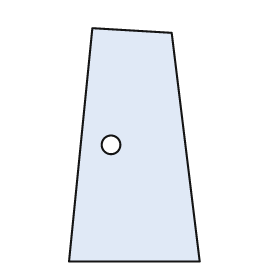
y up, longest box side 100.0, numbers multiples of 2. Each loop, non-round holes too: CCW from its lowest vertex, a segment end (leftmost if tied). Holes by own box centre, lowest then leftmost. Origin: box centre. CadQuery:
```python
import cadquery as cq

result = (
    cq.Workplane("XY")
    .moveTo(-28.0, -50.0)
    .lineTo(28.0, -50.0)
    .lineTo(16.0, 48.0)
    .lineTo(-18.0, 50.0)
    .close()
    .moveTo(-10.0, 0.0)
    .circle(4.0)
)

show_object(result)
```